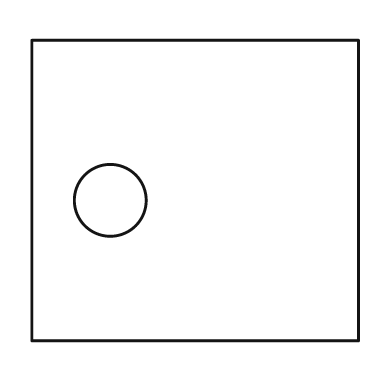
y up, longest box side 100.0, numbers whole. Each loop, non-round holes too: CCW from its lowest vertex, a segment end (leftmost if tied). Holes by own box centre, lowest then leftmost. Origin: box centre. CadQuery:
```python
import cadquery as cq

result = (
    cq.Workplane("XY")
    .moveTo(-50.0, -46.0)
    .lineTo(50.0, -46.0)
    .lineTo(50.0, 46.0)
    .lineTo(-50.0, 46.0)
    .close()
    .moveTo(-26.0, -3.0)
    .circle(11.0)
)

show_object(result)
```